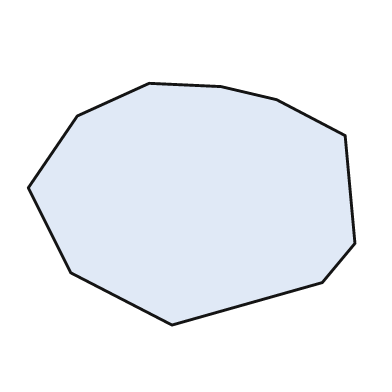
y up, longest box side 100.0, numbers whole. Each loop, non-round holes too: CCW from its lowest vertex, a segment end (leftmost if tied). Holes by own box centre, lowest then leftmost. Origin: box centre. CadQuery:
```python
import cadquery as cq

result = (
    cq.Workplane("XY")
    .moveTo(-6.0, -37.0)
    .lineTo(40.0, -24.0)
    .lineTo(50.0, -12.0)
    .lineTo(47.0, 21.0)
    .lineTo(26.0, 32.0)
    .lineTo(9.0, 36.0)
    .lineTo(-13.0, 37.0)
    .lineTo(-35.0, 27.0)
    .lineTo(-50.0, 5.0)
    .lineTo(-37.0, -21.0)
    .close()
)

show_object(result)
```